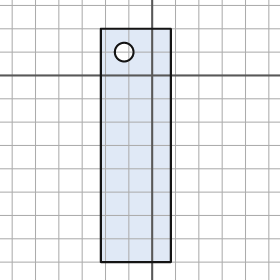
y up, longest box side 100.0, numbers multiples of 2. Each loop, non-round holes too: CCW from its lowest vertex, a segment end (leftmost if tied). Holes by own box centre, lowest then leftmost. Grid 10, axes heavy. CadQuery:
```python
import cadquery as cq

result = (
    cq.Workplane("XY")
    .moveTo(-22.0, -80.0)
    .lineTo(8.0, -80.0)
    .lineTo(8.0, 20.0)
    .lineTo(-22.0, 20.0)
    .close()
    .moveTo(-12.0, 10.0)
    .circle(4.0)
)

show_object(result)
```